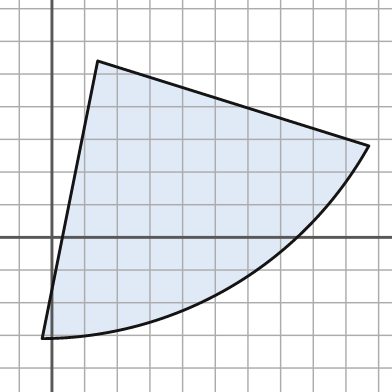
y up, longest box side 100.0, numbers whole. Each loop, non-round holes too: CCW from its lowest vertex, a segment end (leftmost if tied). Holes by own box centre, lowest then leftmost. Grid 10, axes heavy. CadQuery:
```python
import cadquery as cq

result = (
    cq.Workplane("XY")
    .moveTo(-3.0, -31.0)
    .threePointArc((55.0, -15.0), (97.0, 28.0))
    .lineTo(14.0, 54.0)
    .close()
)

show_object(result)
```